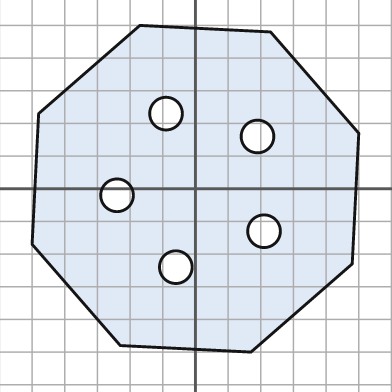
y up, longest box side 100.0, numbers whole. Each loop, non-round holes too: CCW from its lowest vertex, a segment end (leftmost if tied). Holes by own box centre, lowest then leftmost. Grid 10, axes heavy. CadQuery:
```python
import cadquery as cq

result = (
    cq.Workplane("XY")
    .moveTo(17.0, -50.0)
    .lineTo(48.0, -23.0)
    .lineTo(50.0, 17.0)
    .lineTo(23.0, 48.0)
    .lineTo(-17.0, 50.0)
    .lineTo(-48.0, 23.0)
    .lineTo(-50.0, -17.0)
    .lineTo(-23.0, -48.0)
    .close()
    .moveTo(-6.0, -24.0)
    .circle(5.0)
    .moveTo(21.0, -13.0)
    .circle(5.0)
    .moveTo(-24.0, -2.0)
    .circle(5.0)
    .moveTo(19.0, 16.0)
    .circle(5.0)
    .moveTo(-9.0, 23.0)
    .circle(5.0)
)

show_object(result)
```